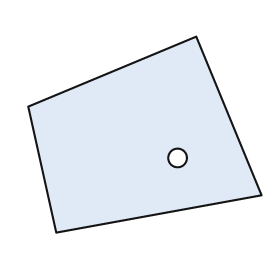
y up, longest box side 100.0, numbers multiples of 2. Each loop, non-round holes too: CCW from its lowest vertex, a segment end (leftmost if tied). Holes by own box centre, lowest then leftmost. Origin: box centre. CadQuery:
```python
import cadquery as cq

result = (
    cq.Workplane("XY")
    .moveTo(-38.0, -42.0)
    .lineTo(50.0, -26.0)
    .lineTo(22.0, 42.0)
    .lineTo(-50.0, 12.0)
    .close()
    .moveTo(14.0, -10.0)
    .circle(4.0)
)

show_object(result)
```